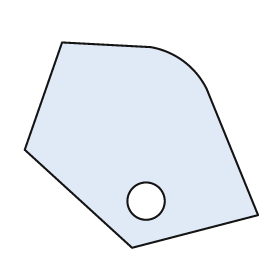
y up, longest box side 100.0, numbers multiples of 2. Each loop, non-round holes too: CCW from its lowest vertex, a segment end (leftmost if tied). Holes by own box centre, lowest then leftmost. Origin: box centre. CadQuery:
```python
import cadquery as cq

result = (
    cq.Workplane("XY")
    .moveTo(-4.0, -44.0)
    .lineTo(50.0, -30.0)
    .lineTo(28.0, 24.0)
    .threePointArc((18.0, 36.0), (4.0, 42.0))
    .lineTo(-34.0, 44.0)
    .lineTo(-50.0, -2.0)
    .close()
    .moveTo(2.0, -24.0)
    .circle(8.0)
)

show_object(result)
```